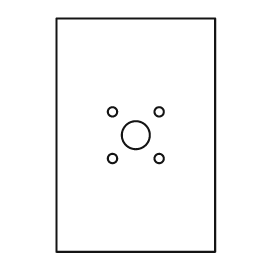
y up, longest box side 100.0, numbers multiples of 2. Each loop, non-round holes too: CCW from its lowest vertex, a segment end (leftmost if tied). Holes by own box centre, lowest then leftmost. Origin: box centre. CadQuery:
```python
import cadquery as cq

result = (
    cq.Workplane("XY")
    .moveTo(-34.0, -50.0)
    .lineTo(34.0, -50.0)
    .lineTo(34.0, 50.0)
    .lineTo(-34.0, 50.0)
    .close()
    .moveTo(-10.0, -10.0)
    .circle(2.0)
    .moveTo(10.0, -10.0)
    .circle(2.0)
    .moveTo(0.0, 0.0)
    .circle(6.0)
    .moveTo(-10.0, 10.0)
    .circle(2.0)
    .moveTo(10.0, 10.0)
    .circle(2.0)
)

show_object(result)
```